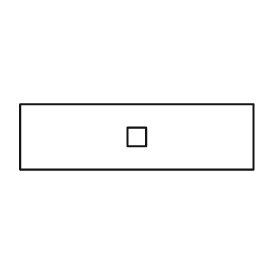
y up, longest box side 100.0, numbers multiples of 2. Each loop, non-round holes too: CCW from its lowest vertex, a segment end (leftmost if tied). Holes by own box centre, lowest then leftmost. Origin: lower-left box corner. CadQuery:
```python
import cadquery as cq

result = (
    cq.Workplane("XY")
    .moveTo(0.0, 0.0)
    .lineTo(100.0, 0.0)
    .lineTo(100.0, 28.0)
    .lineTo(0.0, 28.0)
    .close()
    .moveTo(46.0, 10.0)
    .lineTo(54.0, 10.0)
    .lineTo(54.0, 18.0)
    .lineTo(46.0, 18.0)
    .close()
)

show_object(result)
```